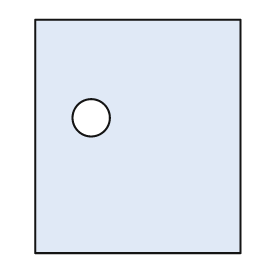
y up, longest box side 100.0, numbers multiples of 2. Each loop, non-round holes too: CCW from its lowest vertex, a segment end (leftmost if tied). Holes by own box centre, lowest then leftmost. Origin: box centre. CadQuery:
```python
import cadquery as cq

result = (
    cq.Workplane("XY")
    .moveTo(-44.0, -50.0)
    .lineTo(44.0, -50.0)
    .lineTo(44.0, 50.0)
    .lineTo(-44.0, 50.0)
    .close()
    .moveTo(-20.0, 8.0)
    .circle(8.0)
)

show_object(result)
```